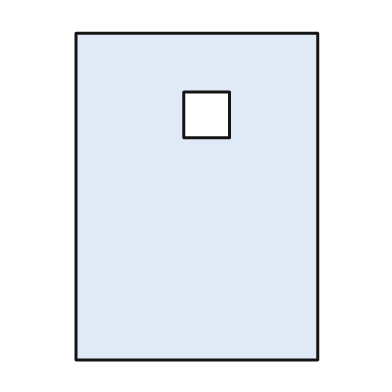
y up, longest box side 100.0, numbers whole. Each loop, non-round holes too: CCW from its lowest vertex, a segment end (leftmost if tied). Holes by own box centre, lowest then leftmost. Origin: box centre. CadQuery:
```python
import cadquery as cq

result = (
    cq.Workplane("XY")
    .moveTo(-37.0, -50.0)
    .lineTo(37.0, -50.0)
    .lineTo(37.0, 50.0)
    .lineTo(-37.0, 50.0)
    .close()
    .moveTo(-4.0, 18.0)
    .lineTo(10.0, 18.0)
    .lineTo(10.0, 32.0)
    .lineTo(-4.0, 32.0)
    .close()
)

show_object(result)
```